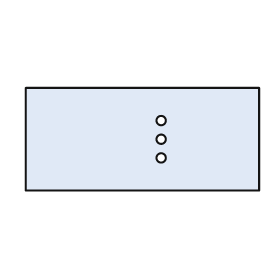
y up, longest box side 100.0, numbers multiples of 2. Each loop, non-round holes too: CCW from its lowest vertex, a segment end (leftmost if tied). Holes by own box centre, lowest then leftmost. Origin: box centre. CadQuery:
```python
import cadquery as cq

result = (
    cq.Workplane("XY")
    .moveTo(-50.0, -22.0)
    .lineTo(50.0, -22.0)
    .lineTo(50.0, 22.0)
    .lineTo(-50.0, 22.0)
    .close()
    .moveTo(8.0, -8.0)
    .circle(2.0)
    .moveTo(8.0, 0.0)
    .circle(2.0)
    .moveTo(8.0, 8.0)
    .circle(2.0)
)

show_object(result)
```